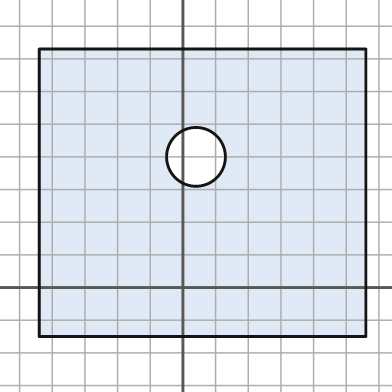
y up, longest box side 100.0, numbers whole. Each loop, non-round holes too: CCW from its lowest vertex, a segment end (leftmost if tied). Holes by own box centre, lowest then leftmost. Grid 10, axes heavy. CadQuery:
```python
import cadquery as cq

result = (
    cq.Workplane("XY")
    .moveTo(-44.0, -15.0)
    .lineTo(56.0, -15.0)
    .lineTo(56.0, 73.0)
    .lineTo(-44.0, 73.0)
    .close()
    .moveTo(4.0, 40.0)
    .circle(9.0)
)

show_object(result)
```